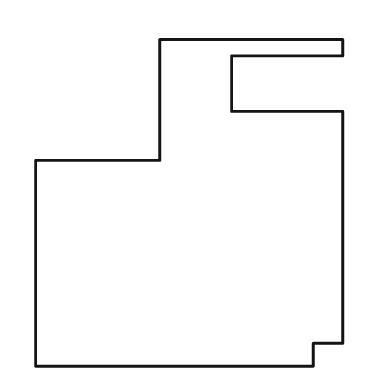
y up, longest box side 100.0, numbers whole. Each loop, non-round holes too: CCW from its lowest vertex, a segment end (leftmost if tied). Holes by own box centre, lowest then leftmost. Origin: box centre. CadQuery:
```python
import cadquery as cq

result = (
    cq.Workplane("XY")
    .moveTo(-47.0, -50.0)
    .lineTo(38.0, -50.0)
    .lineTo(38.0, -43.0)
    .lineTo(47.0, -43.0)
    .lineTo(47.0, 28.0)
    .lineTo(13.0, 28.0)
    .lineTo(13.0, 45.0)
    .lineTo(47.0, 45.0)
    .lineTo(47.0, 50.0)
    .lineTo(-9.0, 50.0)
    .lineTo(-9.0, 13.0)
    .lineTo(-47.0, 13.0)
    .close()
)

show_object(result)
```